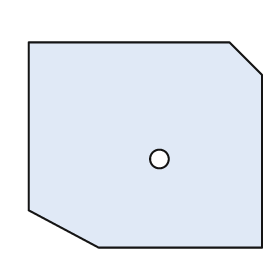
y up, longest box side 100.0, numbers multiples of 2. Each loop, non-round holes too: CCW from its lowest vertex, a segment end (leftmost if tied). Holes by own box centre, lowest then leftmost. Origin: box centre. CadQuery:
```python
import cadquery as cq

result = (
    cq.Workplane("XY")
    .moveTo(-20.0, -44.0)
    .lineTo(50.0, -44.0)
    .lineTo(50.0, 30.0)
    .lineTo(36.0, 44.0)
    .lineTo(-50.0, 44.0)
    .lineTo(-50.0, -28.0)
    .close()
    .moveTo(6.0, -6.0)
    .circle(4.0)
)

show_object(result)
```